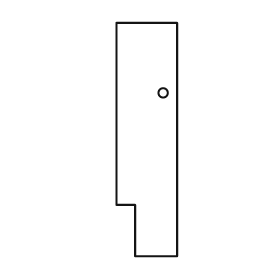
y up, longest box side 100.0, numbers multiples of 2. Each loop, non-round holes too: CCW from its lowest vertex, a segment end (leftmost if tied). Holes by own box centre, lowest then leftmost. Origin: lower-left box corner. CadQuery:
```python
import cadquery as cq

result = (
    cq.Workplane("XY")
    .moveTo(8.0, 0.0)
    .lineTo(26.0, 0.0)
    .lineTo(26.0, 100.0)
    .lineTo(0.0, 100.0)
    .lineTo(0.0, 22.0)
    .lineTo(8.0, 22.0)
    .close()
    .moveTo(20.0, 70.0)
    .circle(2.0)
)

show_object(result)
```